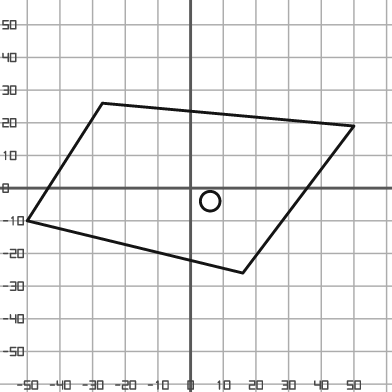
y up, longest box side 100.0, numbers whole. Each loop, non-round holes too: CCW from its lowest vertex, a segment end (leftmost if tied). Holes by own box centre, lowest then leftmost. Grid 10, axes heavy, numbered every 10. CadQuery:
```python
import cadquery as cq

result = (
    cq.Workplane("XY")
    .moveTo(16.0, -26.0)
    .lineTo(50.0, 19.0)
    .lineTo(-27.0, 26.0)
    .lineTo(-50.0, -10.0)
    .close()
    .moveTo(6.0, -4.0)
    .circle(3.0)
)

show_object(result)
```